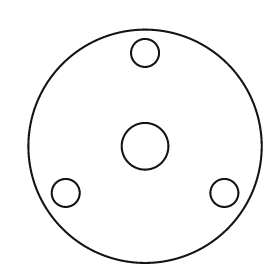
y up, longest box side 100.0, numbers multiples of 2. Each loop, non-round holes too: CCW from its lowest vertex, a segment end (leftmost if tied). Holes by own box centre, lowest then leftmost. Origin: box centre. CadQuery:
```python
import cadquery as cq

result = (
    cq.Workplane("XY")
    .moveTo(0.0, 0.0)
    .circle(50.0)
    .moveTo(-34.0, -20.0)
    .circle(6.0)
    .moveTo(34.0, -20.0)
    .circle(6.0)
    .moveTo(0.0, 0.0)
    .circle(10.0)
    .moveTo(0.0, 40.0)
    .circle(6.0)
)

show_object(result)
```